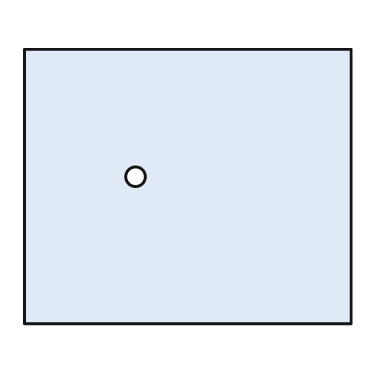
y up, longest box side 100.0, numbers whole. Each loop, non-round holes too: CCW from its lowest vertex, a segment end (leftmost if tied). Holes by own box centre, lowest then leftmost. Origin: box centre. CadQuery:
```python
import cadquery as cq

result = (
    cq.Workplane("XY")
    .moveTo(-50.0, -42.0)
    .lineTo(50.0, -42.0)
    .lineTo(50.0, 42.0)
    .lineTo(-50.0, 42.0)
    .close()
    .moveTo(-16.0, 3.0)
    .circle(3.0)
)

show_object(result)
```